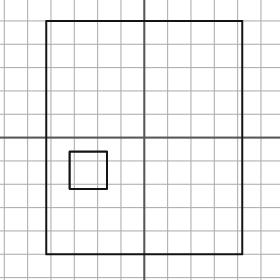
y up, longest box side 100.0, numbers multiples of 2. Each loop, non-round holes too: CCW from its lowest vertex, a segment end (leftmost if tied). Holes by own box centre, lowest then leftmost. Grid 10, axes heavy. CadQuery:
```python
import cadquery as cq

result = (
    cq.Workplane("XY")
    .moveTo(-42.0, -50.0)
    .lineTo(42.0, -50.0)
    .lineTo(42.0, 50.0)
    .lineTo(-42.0, 50.0)
    .close()
    .moveTo(-32.0, -22.0)
    .lineTo(-16.0, -22.0)
    .lineTo(-16.0, -6.0)
    .lineTo(-32.0, -6.0)
    .close()
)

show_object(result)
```